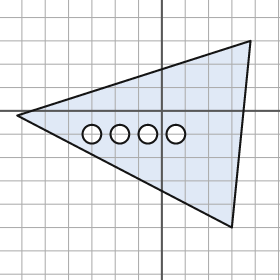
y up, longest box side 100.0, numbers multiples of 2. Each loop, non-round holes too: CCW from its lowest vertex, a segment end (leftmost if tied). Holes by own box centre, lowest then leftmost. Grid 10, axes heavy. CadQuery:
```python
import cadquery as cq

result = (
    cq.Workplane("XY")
    .moveTo(30.0, -50.0)
    .lineTo(38.0, 30.0)
    .lineTo(-62.0, -2.0)
    .close()
    .moveTo(-30.0, -10.0)
    .circle(4.0)
    .moveTo(-18.0, -10.0)
    .circle(4.0)
    .moveTo(-6.0, -10.0)
    .circle(4.0)
    .moveTo(6.0, -10.0)
    .circle(4.0)
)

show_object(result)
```